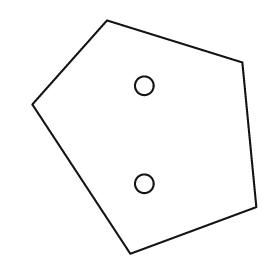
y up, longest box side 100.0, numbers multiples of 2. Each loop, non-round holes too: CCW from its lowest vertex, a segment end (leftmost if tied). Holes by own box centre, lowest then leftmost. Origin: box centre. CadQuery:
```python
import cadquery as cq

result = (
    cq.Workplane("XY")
    .moveTo(-6.0, -50.0)
    .lineTo(48.0, -30.0)
    .lineTo(42.0, 32.0)
    .lineTo(-16.0, 50.0)
    .lineTo(-48.0, 14.0)
    .close()
    .moveTo(0.0, -20.0)
    .circle(4.0)
    .moveTo(0.0, 22.0)
    .circle(4.0)
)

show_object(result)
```